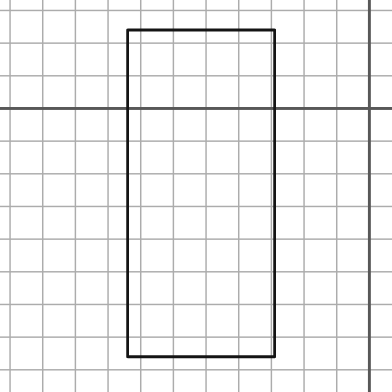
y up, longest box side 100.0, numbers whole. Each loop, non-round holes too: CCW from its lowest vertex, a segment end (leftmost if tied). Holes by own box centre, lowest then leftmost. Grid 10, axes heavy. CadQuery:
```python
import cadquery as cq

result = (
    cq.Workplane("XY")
    .moveTo(-74.0, -76.0)
    .lineTo(-29.0, -76.0)
    .lineTo(-29.0, 24.0)
    .lineTo(-74.0, 24.0)
    .close()
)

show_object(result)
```